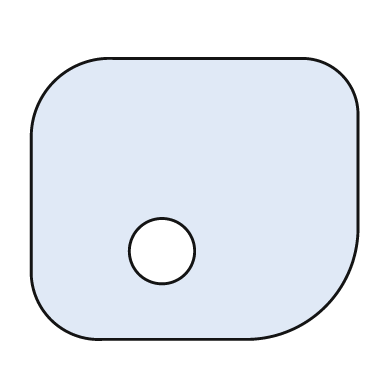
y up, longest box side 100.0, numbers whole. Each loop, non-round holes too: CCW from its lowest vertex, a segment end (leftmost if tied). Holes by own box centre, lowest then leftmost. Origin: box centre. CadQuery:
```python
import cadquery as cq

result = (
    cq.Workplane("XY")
    .moveTo(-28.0, -43.0)
    .lineTo(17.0, -43.0)
    .threePointArc((40.0, -33.0), (50.0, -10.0))
    .lineTo(50.0, 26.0)
    .threePointArc((45.0, 38.0), (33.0, 43.0))
    .lineTo(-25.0, 43.0)
    .threePointArc((-43.0, 36.0), (-50.0, 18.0))
    .lineTo(-50.0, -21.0)
    .threePointArc((-44.0, -37.0), (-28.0, -43.0))
    .close()
    .moveTo(-10.0, -16.0)
    .circle(10.0)
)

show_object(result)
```